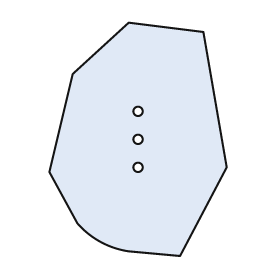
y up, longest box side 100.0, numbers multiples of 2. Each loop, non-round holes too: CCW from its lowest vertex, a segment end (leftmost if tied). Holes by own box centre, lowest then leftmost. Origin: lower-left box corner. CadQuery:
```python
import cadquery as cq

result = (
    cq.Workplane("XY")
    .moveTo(56.0, 0.0)
    .lineTo(76.0, 38.0)
    .lineTo(66.0, 96.0)
    .lineTo(34.0, 100.0)
    .lineTo(10.0, 78.0)
    .lineTo(0.0, 36.0)
    .lineTo(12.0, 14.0)
    .threePointArc((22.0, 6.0), (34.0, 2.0))
    .close()
    .moveTo(38.0, 38.0)
    .circle(2.0)
    .moveTo(38.0, 50.0)
    .circle(2.0)
    .moveTo(38.0, 62.0)
    .circle(2.0)
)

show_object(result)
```